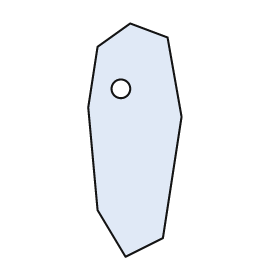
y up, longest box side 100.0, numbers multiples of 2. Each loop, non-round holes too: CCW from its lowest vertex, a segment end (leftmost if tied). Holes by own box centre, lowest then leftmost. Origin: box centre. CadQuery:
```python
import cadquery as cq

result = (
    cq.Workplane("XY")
    .moveTo(-4.0, -50.0)
    .lineTo(12.0, -42.0)
    .lineTo(20.0, 10.0)
    .lineTo(14.0, 44.0)
    .lineTo(-2.0, 50.0)
    .lineTo(-16.0, 40.0)
    .lineTo(-20.0, 14.0)
    .lineTo(-16.0, -30.0)
    .close()
    .moveTo(-6.0, 22.0)
    .circle(4.0)
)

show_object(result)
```